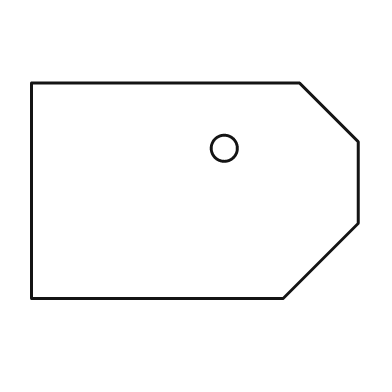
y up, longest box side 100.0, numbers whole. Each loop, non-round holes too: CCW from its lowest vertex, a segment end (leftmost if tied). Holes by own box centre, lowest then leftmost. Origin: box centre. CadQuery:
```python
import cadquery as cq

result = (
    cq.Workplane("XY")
    .moveTo(-50.0, -33.0)
    .lineTo(27.0, -33.0)
    .lineTo(50.0, -10.0)
    .lineTo(50.0, 15.0)
    .lineTo(32.0, 33.0)
    .lineTo(-50.0, 33.0)
    .close()
    .moveTo(9.0, 13.0)
    .circle(4.0)
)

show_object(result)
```